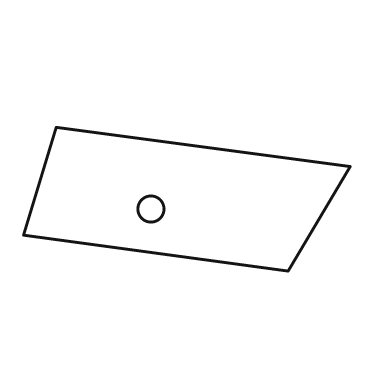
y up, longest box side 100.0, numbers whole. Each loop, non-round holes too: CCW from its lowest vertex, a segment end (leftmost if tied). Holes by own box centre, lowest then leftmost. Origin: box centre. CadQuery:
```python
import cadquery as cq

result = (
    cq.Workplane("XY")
    .moveTo(31.0, -22.0)
    .lineTo(50.0, 10.0)
    .lineTo(-40.0, 22.0)
    .lineTo(-50.0, -11.0)
    .close()
    .moveTo(-11.0, -3.0)
    .circle(4.0)
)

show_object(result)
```